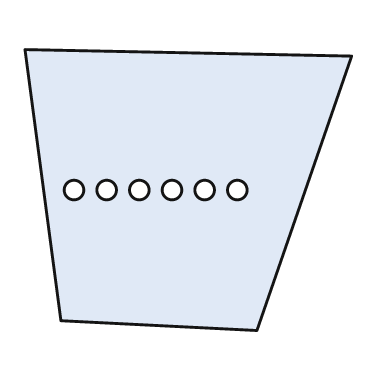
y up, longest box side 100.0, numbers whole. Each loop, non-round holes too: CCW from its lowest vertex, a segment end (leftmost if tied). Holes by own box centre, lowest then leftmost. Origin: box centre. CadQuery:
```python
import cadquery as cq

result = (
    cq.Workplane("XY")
    .moveTo(21.0, -43.0)
    .lineTo(50.0, 41.0)
    .lineTo(-50.0, 43.0)
    .lineTo(-39.0, -40.0)
    .close()
    .moveTo(-35.0, 0.0)
    .circle(3.0)
    .moveTo(-25.0, 0.0)
    .circle(3.0)
    .moveTo(-15.0, 0.0)
    .circle(3.0)
    .moveTo(-5.0, 0.0)
    .circle(3.0)
    .moveTo(5.0, 0.0)
    .circle(3.0)
    .moveTo(15.0, 0.0)
    .circle(3.0)
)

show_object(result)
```